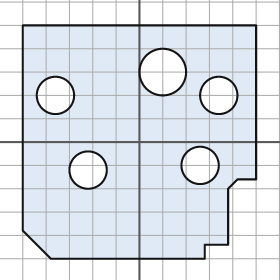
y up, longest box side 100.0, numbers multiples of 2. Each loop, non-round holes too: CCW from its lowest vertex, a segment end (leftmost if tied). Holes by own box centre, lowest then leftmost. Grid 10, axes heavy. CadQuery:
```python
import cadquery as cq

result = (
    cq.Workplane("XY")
    .moveTo(-38.0, -50.0)
    .lineTo(28.0, -50.0)
    .lineTo(28.0, -44.0)
    .lineTo(38.0, -44.0)
    .lineTo(38.0, -20.0)
    .lineTo(42.0, -16.0)
    .lineTo(50.0, -16.0)
    .lineTo(50.0, 50.0)
    .lineTo(-50.0, 50.0)
    .lineTo(-50.0, -38.0)
    .close()
    .moveTo(-22.0, -12.0)
    .circle(8.0)
    .moveTo(26.0, -10.0)
    .circle(8.0)
    .moveTo(-36.0, 20.0)
    .circle(8.0)
    .moveTo(34.0, 20.0)
    .circle(8.0)
    .moveTo(10.0, 30.0)
    .circle(10.0)
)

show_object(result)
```